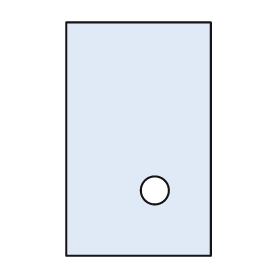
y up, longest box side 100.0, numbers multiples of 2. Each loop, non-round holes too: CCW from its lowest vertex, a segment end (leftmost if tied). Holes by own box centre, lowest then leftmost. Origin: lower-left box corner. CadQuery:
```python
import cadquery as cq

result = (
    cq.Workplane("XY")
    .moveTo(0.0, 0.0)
    .lineTo(62.0, 0.0)
    .lineTo(62.0, 100.0)
    .lineTo(0.0, 100.0)
    .close()
    .moveTo(38.0, 28.0)
    .circle(6.0)
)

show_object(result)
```